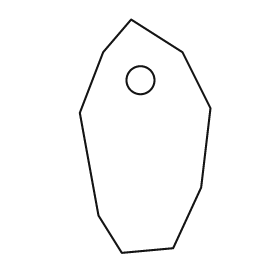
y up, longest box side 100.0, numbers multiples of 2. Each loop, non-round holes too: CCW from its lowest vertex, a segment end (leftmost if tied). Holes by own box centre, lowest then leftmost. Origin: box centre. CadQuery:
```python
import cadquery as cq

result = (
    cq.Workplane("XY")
    .moveTo(-10.0, -50.0)
    .lineTo(12.0, -48.0)
    .lineTo(24.0, -22.0)
    .lineTo(28.0, 12.0)
    .lineTo(16.0, 36.0)
    .lineTo(-6.0, 50.0)
    .lineTo(-18.0, 36.0)
    .lineTo(-28.0, 10.0)
    .lineTo(-20.0, -34.0)
    .close()
    .moveTo(-2.0, 24.0)
    .circle(6.0)
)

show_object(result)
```